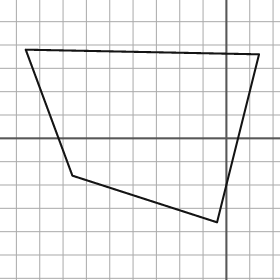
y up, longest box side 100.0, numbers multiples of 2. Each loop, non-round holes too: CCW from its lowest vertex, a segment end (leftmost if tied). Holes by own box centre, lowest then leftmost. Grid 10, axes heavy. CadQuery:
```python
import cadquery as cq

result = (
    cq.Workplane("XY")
    .moveTo(-4.0, -36.0)
    .lineTo(14.0, 36.0)
    .lineTo(-86.0, 38.0)
    .lineTo(-66.0, -16.0)
    .close()
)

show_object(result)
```